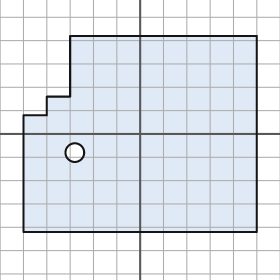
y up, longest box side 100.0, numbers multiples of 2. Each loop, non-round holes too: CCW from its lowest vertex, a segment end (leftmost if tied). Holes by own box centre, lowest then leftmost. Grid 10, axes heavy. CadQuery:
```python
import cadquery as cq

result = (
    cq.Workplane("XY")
    .moveTo(-50.0, -42.0)
    .lineTo(50.0, -42.0)
    .lineTo(50.0, 42.0)
    .lineTo(-30.0, 42.0)
    .lineTo(-30.0, 16.0)
    .lineTo(-40.0, 16.0)
    .lineTo(-40.0, 8.0)
    .lineTo(-50.0, 8.0)
    .close()
    .moveTo(-28.0, -8.0)
    .circle(4.0)
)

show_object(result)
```